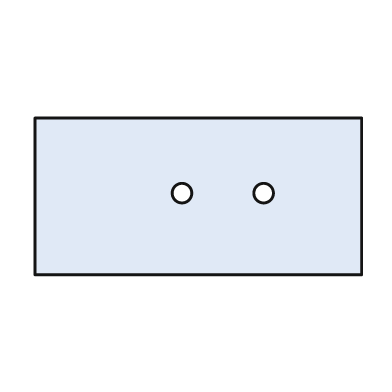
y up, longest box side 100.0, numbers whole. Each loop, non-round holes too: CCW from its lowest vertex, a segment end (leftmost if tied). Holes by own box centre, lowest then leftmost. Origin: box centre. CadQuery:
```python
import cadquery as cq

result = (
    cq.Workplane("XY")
    .moveTo(-50.0, -24.0)
    .lineTo(50.0, -24.0)
    .lineTo(50.0, 24.0)
    .lineTo(-50.0, 24.0)
    .close()
    .moveTo(-5.0, 1.0)
    .circle(3.0)
    .moveTo(20.0, 1.0)
    .circle(3.0)
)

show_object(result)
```